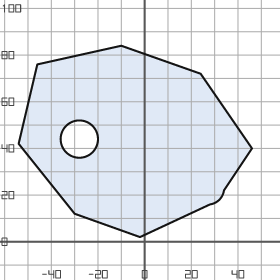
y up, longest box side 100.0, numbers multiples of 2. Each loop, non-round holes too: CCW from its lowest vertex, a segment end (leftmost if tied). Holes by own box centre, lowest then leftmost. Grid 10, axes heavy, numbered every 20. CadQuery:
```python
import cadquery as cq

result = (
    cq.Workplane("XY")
    .moveTo(-2.0, 2.0)
    .lineTo(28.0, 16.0)
    .threePointArc((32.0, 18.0), (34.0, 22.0))
    .lineTo(46.0, 40.0)
    .lineTo(24.0, 72.0)
    .lineTo(-10.0, 84.0)
    .lineTo(-46.0, 76.0)
    .lineTo(-54.0, 42.0)
    .lineTo(-30.0, 12.0)
    .close()
    .moveTo(-28.0, 44.0)
    .circle(8.0)
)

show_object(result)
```